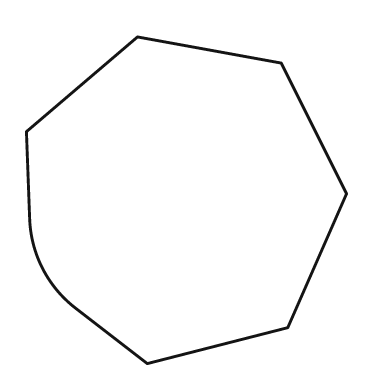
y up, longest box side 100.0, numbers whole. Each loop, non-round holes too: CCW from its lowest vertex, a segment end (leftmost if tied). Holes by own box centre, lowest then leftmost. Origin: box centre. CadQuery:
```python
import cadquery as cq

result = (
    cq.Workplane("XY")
    .moveTo(-12.0, -50.0)
    .lineTo(31.0, -39.0)
    .lineTo(49.0, 2.0)
    .lineTo(29.0, 42.0)
    .lineTo(-15.0, 50.0)
    .lineTo(-49.0, 21.0)
    .lineTo(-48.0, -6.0)
    .threePointArc((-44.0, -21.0), (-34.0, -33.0))
    .close()
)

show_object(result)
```